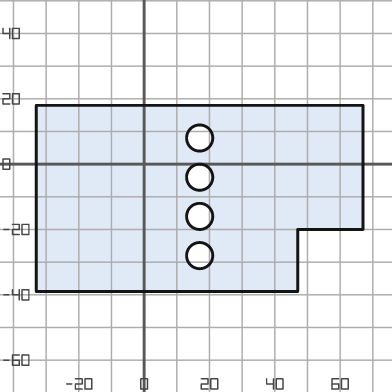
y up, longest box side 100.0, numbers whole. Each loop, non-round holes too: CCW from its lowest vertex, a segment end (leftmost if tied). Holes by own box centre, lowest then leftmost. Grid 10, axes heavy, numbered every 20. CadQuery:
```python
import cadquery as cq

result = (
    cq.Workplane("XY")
    .moveTo(-33.0, -39.0)
    .lineTo(47.0, -39.0)
    .lineTo(47.0, -20.0)
    .lineTo(67.0, -20.0)
    .lineTo(67.0, 18.0)
    .lineTo(-33.0, 18.0)
    .close()
    .moveTo(17.0, -28.0)
    .circle(4.0)
    .moveTo(17.0, -16.0)
    .circle(4.0)
    .moveTo(17.0, -4.0)
    .circle(4.0)
    .moveTo(17.0, 8.0)
    .circle(4.0)
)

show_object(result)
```